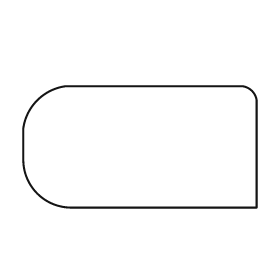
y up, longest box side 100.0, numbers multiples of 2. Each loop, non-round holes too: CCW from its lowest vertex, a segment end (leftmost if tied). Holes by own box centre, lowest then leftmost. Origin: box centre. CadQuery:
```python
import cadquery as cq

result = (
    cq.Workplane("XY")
    .moveTo(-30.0, -26.0)
    .lineTo(50.0, -26.0)
    .lineTo(50.0, 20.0)
    .threePointArc((48.0, 24.0), (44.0, 26.0))
    .lineTo(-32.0, 26.0)
    .threePointArc((-44.0, 20.0), (-50.0, 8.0))
    .lineTo(-50.0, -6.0)
    .threePointArc((-44.0, -20.0), (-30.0, -26.0))
    .close()
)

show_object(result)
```